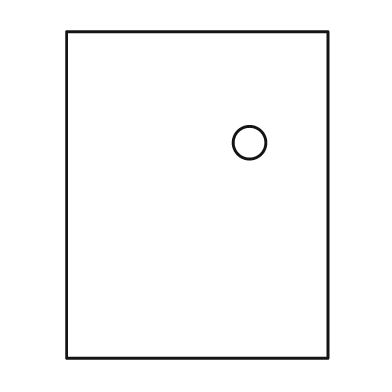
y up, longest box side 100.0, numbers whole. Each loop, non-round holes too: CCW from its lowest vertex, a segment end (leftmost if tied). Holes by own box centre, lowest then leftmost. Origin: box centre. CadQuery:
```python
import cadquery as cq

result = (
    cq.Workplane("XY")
    .moveTo(-40.0, -50.0)
    .lineTo(40.0, -50.0)
    .lineTo(40.0, 50.0)
    .lineTo(-40.0, 50.0)
    .close()
    .moveTo(16.0, 16.0)
    .circle(5.0)
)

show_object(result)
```